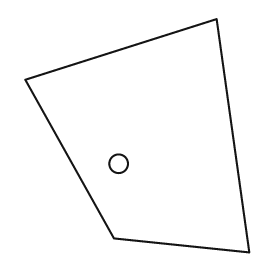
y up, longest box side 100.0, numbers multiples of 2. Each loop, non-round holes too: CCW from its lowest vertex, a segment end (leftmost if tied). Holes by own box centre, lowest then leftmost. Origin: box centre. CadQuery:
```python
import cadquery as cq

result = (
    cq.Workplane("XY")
    .moveTo(48.0, -50.0)
    .lineTo(34.0, 50.0)
    .lineTo(-48.0, 24.0)
    .lineTo(-10.0, -44.0)
    .close()
    .moveTo(-8.0, -12.0)
    .circle(4.0)
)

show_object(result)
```